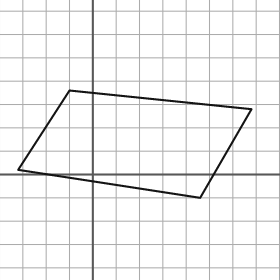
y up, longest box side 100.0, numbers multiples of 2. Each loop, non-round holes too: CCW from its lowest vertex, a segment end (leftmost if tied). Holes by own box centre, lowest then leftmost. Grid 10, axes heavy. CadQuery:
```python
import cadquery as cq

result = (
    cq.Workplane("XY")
    .moveTo(46.0, -10.0)
    .lineTo(68.0, 28.0)
    .lineTo(-10.0, 36.0)
    .lineTo(-32.0, 2.0)
    .close()
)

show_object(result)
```